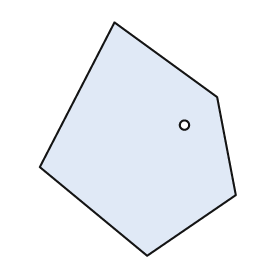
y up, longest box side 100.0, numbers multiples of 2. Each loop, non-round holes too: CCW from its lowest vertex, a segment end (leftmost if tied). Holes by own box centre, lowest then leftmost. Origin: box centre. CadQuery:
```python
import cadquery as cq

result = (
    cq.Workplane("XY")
    .moveTo(4.0, -50.0)
    .lineTo(42.0, -24.0)
    .lineTo(34.0, 18.0)
    .lineTo(-10.0, 50.0)
    .lineTo(-42.0, -12.0)
    .close()
    .moveTo(20.0, 6.0)
    .circle(2.0)
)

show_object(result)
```